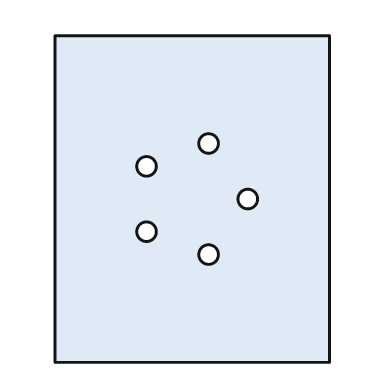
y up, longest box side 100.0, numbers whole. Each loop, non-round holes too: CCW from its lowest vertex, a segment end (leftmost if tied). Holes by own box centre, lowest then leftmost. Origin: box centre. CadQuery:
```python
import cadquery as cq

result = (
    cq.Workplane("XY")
    .moveTo(-42.0, -50.0)
    .lineTo(42.0, -50.0)
    .lineTo(42.0, 50.0)
    .lineTo(-42.0, 50.0)
    .close()
    .moveTo(5.0, -17.0)
    .circle(3.0)
    .moveTo(-14.0, -10.0)
    .circle(3.0)
    .moveTo(17.0, 0.0)
    .circle(3.0)
    .moveTo(-14.0, 10.0)
    .circle(3.0)
    .moveTo(5.0, 17.0)
    .circle(3.0)
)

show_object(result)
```